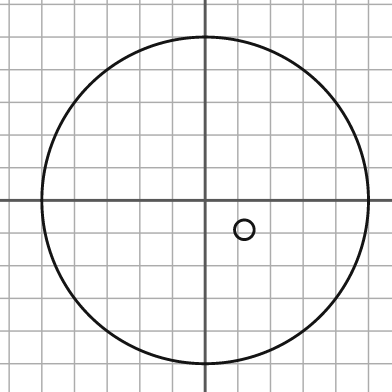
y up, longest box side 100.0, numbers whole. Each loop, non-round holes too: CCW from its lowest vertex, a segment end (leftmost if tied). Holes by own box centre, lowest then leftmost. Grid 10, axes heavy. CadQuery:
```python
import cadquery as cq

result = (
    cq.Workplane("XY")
    .moveTo(0.0, 0.0)
    .circle(50.0)
    .moveTo(12.0, -9.0)
    .circle(3.0)
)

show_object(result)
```